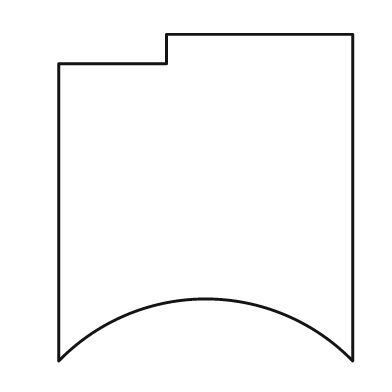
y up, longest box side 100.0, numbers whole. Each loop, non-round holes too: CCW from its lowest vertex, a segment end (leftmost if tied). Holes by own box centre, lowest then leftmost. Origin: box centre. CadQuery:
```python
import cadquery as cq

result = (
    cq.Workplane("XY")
    .moveTo(-45.0, -50.0)
    .threePointArc((0.0, -31.0), (45.0, -50.0))
    .lineTo(45.0, 50.0)
    .lineTo(-12.0, 50.0)
    .lineTo(-12.0, 41.0)
    .lineTo(-45.0, 41.0)
    .close()
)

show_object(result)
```